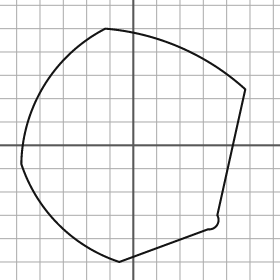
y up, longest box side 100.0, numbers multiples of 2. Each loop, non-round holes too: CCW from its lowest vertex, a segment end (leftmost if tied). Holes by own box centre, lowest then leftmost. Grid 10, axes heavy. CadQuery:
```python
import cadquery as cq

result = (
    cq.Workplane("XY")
    .moveTo(-6.0, -50.0)
    .lineTo(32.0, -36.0)
    .threePointArc((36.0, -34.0), (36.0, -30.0))
    .lineTo(48.0, 24.0)
    .threePointArc((20.0, 42.0), (-12.0, 50.0))
    .threePointArc((-38.0, 26.0), (-48.0, -8.0))
    .threePointArc((-32.0, -34.0), (-6.0, -50.0))
    .close()
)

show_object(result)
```